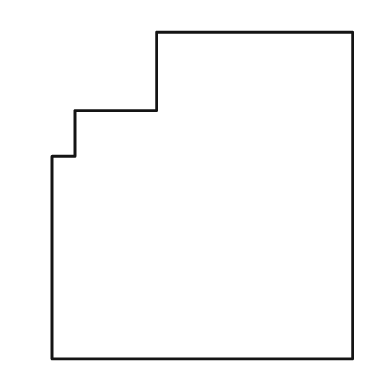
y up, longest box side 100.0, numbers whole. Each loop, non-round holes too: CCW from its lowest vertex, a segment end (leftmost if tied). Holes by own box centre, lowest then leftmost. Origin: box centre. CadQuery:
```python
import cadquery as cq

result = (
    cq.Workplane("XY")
    .moveTo(-46.0, -50.0)
    .lineTo(46.0, -50.0)
    .lineTo(46.0, 50.0)
    .lineTo(-14.0, 50.0)
    .lineTo(-14.0, 26.0)
    .lineTo(-39.0, 26.0)
    .lineTo(-39.0, 12.0)
    .lineTo(-46.0, 12.0)
    .close()
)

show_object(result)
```